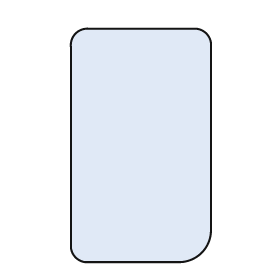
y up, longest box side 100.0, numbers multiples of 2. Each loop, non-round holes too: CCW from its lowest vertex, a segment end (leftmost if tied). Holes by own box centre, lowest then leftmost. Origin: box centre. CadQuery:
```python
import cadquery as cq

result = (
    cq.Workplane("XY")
    .moveTo(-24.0, -50.0)
    .lineTo(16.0, -50.0)
    .threePointArc((26.0, -46.0), (30.0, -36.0))
    .lineTo(30.0, 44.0)
    .threePointArc((28.0, 48.0), (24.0, 50.0))
    .lineTo(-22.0, 50.0)
    .threePointArc((-28.0, 48.0), (-30.0, 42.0))
    .lineTo(-30.0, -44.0)
    .threePointArc((-28.0, -48.0), (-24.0, -50.0))
    .close()
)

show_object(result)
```